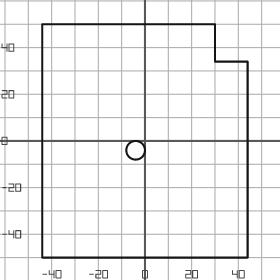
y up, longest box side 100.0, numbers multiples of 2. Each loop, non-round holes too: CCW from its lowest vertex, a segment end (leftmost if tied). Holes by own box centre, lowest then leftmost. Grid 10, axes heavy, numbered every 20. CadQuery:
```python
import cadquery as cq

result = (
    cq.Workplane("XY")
    .moveTo(-44.0, -50.0)
    .lineTo(44.0, -50.0)
    .lineTo(44.0, 34.0)
    .lineTo(30.0, 34.0)
    .lineTo(30.0, 50.0)
    .lineTo(-44.0, 50.0)
    .close()
    .moveTo(-4.0, -4.0)
    .circle(4.0)
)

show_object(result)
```